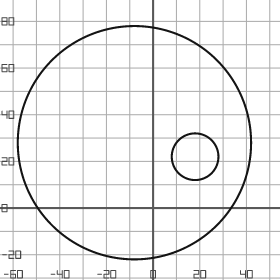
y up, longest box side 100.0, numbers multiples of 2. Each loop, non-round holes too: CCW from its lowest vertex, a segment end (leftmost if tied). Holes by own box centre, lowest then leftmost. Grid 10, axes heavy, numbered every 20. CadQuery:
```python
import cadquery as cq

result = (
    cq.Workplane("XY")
    .moveTo(-8.0, 28.0)
    .circle(50.0)
    .moveTo(18.0, 22.0)
    .circle(10.0)
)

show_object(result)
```